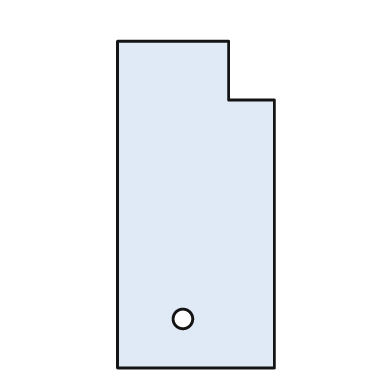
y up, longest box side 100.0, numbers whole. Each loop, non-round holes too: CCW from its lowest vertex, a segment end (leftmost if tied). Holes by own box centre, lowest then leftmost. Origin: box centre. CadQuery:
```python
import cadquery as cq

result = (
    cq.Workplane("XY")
    .moveTo(-24.0, -50.0)
    .lineTo(24.0, -50.0)
    .lineTo(24.0, 32.0)
    .lineTo(10.0, 32.0)
    .lineTo(10.0, 50.0)
    .lineTo(-24.0, 50.0)
    .close()
    .moveTo(-4.0, -35.0)
    .circle(3.0)
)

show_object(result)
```